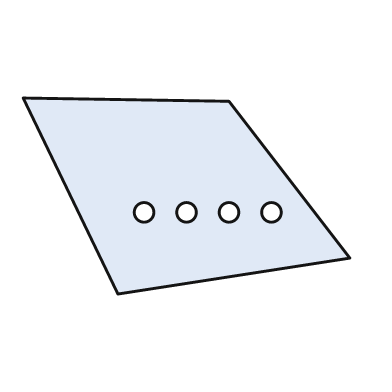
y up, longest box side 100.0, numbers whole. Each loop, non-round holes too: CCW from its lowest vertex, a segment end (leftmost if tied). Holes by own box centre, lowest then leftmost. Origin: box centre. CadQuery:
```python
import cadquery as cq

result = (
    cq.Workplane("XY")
    .moveTo(-21.0, -30.0)
    .lineTo(50.0, -19.0)
    .lineTo(13.0, 29.0)
    .lineTo(-50.0, 30.0)
    .close()
    .moveTo(-13.0, -5.0)
    .circle(3.0)
    .moveTo(0.0, -5.0)
    .circle(3.0)
    .moveTo(13.0, -5.0)
    .circle(3.0)
    .moveTo(26.0, -5.0)
    .circle(3.0)
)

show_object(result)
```